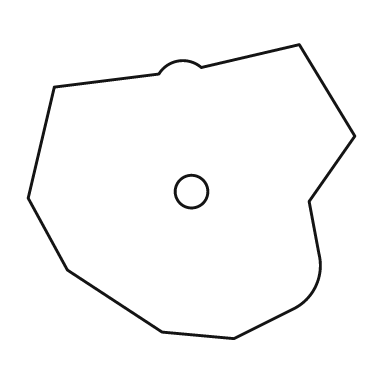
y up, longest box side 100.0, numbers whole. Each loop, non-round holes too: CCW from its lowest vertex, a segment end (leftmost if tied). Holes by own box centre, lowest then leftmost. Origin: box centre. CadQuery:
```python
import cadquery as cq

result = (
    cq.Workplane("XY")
    .moveTo(13.0, -45.0)
    .lineTo(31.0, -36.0)
    .threePointArc((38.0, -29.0), (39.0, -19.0))
    .lineTo(36.0, -3.0)
    .lineTo(50.0, 17.0)
    .lineTo(33.0, 45.0)
    .lineTo(3.0, 38.0)
    .threePointArc((-4.0, 40.0), (-10.0, 36.0))
    .lineTo(-42.0, 32.0)
    .lineTo(-50.0, -2.0)
    .lineTo(-38.0, -24.0)
    .lineTo(-9.0, -43.0)
    .close()
    .moveTo(0.0, 0.0)
    .circle(5.0)
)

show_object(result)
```